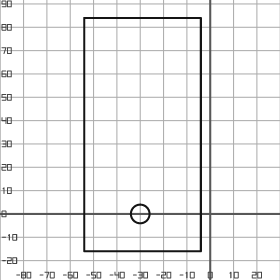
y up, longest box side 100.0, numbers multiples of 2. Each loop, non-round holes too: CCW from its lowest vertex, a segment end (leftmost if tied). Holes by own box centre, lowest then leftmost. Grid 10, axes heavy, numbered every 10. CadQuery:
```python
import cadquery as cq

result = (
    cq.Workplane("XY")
    .moveTo(-54.0, -16.0)
    .lineTo(-4.0, -16.0)
    .lineTo(-4.0, 84.0)
    .lineTo(-54.0, 84.0)
    .close()
    .moveTo(-30.0, 0.0)
    .circle(4.0)
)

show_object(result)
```